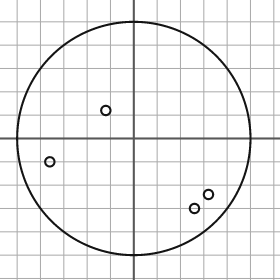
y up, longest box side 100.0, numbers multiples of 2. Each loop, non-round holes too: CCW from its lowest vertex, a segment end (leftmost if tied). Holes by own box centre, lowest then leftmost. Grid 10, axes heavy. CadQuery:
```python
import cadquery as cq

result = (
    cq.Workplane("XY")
    .moveTo(0.0, 0.0)
    .circle(50.0)
    .moveTo(26.0, -30.0)
    .circle(2.0)
    .moveTo(32.0, -24.0)
    .circle(2.0)
    .moveTo(-36.0, -10.0)
    .circle(2.0)
    .moveTo(-12.0, 12.0)
    .circle(2.0)
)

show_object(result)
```